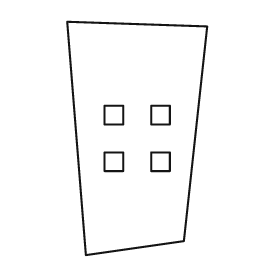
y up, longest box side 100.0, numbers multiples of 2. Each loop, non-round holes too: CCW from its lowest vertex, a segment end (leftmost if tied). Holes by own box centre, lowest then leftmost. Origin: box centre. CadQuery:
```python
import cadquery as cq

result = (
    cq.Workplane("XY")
    .moveTo(-22.0, -50.0)
    .lineTo(20.0, -44.0)
    .lineTo(30.0, 48.0)
    .lineTo(-30.0, 50.0)
    .close()
    .moveTo(-14.0, -14.0)
    .lineTo(-6.0, -14.0)
    .lineTo(-6.0, -6.0)
    .lineTo(-14.0, -6.0)
    .close()
    .moveTo(6.0, -14.0)
    .lineTo(14.0, -14.0)
    .lineTo(14.0, -6.0)
    .lineTo(6.0, -6.0)
    .close()
    .moveTo(-14.0, 6.0)
    .lineTo(-6.0, 6.0)
    .lineTo(-6.0, 14.0)
    .lineTo(-14.0, 14.0)
    .close()
    .moveTo(6.0, 6.0)
    .lineTo(14.0, 6.0)
    .lineTo(14.0, 14.0)
    .lineTo(6.0, 14.0)
    .close()
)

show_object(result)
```